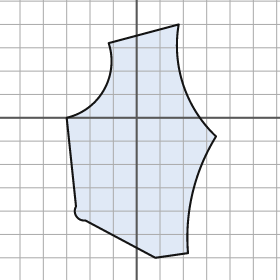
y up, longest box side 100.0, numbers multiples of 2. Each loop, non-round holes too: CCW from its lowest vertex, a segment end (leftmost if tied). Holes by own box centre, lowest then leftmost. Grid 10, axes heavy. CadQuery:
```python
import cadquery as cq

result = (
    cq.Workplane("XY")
    .moveTo(8.0, -60.0)
    .lineTo(22.0, -58.0)
    .threePointArc((24.0, -32.0), (34.0, -8.0))
    .threePointArc((20.0, 14.0), (18.0, 40.0))
    .lineTo(-12.0, 32.0)
    .threePointArc((-14.0, 12.0), (-30.0, 0.0))
    .lineTo(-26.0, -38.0)
    .threePointArc((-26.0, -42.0), (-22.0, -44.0))
    .close()
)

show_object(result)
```